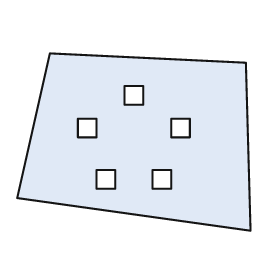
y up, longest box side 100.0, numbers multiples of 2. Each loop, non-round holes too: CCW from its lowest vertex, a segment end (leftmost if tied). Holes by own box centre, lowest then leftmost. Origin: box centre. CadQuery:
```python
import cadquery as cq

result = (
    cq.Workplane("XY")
    .moveTo(50.0, -38.0)
    .lineTo(48.0, 34.0)
    .lineTo(-36.0, 38.0)
    .lineTo(-50.0, -24.0)
    .close()
    .moveTo(-16.0, -20.0)
    .lineTo(-8.0, -20.0)
    .lineTo(-8.0, -12.0)
    .lineTo(-16.0, -12.0)
    .close()
    .moveTo(8.0, -20.0)
    .lineTo(16.0, -20.0)
    .lineTo(16.0, -12.0)
    .lineTo(8.0, -12.0)
    .close()
    .moveTo(-24.0, 2.0)
    .lineTo(-16.0, 2.0)
    .lineTo(-16.0, 10.0)
    .lineTo(-24.0, 10.0)
    .close()
    .moveTo(16.0, 2.0)
    .lineTo(24.0, 2.0)
    .lineTo(24.0, 10.0)
    .lineTo(16.0, 10.0)
    .close()
    .moveTo(-4.0, 16.0)
    .lineTo(4.0, 16.0)
    .lineTo(4.0, 24.0)
    .lineTo(-4.0, 24.0)
    .close()
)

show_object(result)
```